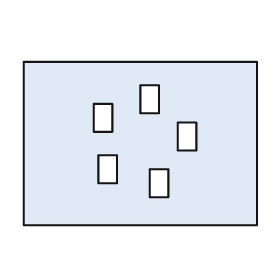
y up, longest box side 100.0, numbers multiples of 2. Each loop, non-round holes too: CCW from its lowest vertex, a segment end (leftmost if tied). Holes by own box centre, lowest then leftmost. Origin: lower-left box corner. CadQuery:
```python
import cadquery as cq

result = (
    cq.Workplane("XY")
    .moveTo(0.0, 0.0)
    .lineTo(100.0, 0.0)
    .lineTo(100.0, 70.0)
    .lineTo(0.0, 70.0)
    .close()
    .moveTo(54.0, 12.0)
    .lineTo(62.0, 12.0)
    .lineTo(62.0, 24.0)
    .lineTo(54.0, 24.0)
    .close()
    .moveTo(32.0, 18.0)
    .lineTo(40.0, 18.0)
    .lineTo(40.0, 30.0)
    .lineTo(32.0, 30.0)
    .close()
    .moveTo(66.0, 32.0)
    .lineTo(74.0, 32.0)
    .lineTo(74.0, 44.0)
    .lineTo(66.0, 44.0)
    .close()
    .moveTo(30.0, 40.0)
    .lineTo(38.0, 40.0)
    .lineTo(38.0, 52.0)
    .lineTo(30.0, 52.0)
    .close()
    .moveTo(50.0, 48.0)
    .lineTo(58.0, 48.0)
    .lineTo(58.0, 60.0)
    .lineTo(50.0, 60.0)
    .close()
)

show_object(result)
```